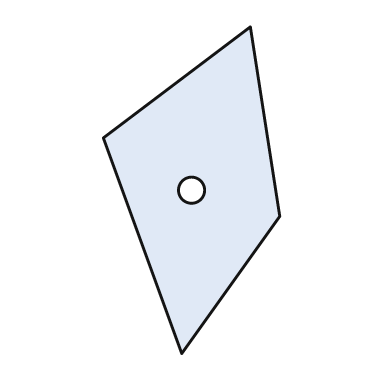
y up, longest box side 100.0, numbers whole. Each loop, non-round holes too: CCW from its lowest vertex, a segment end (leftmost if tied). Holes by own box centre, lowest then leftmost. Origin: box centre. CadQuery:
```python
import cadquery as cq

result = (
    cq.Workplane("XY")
    .moveTo(-3.0, -50.0)
    .lineTo(27.0, -8.0)
    .lineTo(18.0, 50.0)
    .lineTo(-27.0, 16.0)
    .close()
    .moveTo(0.0, 0.0)
    .circle(4.0)
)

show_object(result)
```